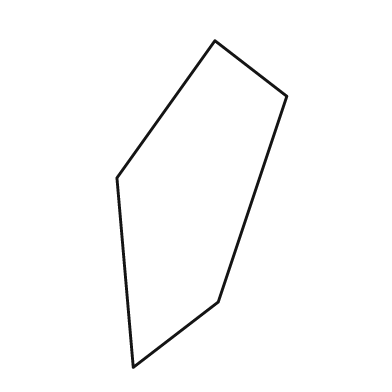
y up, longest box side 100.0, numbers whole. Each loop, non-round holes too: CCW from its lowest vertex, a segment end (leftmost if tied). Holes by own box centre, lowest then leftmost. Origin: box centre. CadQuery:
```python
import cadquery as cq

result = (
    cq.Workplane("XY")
    .moveTo(-21.0, -50.0)
    .lineTo(5.0, -30.0)
    .lineTo(26.0, 33.0)
    .lineTo(4.0, 50.0)
    .lineTo(-26.0, 8.0)
    .close()
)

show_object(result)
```